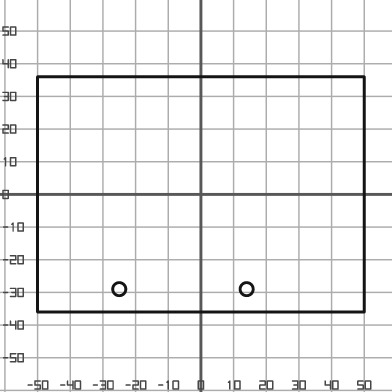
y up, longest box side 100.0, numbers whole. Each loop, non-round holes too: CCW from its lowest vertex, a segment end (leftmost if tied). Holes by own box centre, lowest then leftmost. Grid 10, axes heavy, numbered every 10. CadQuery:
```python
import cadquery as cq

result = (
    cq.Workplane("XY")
    .moveTo(-50.0, -36.0)
    .lineTo(50.0, -36.0)
    .lineTo(50.0, 36.0)
    .lineTo(-50.0, 36.0)
    .close()
    .moveTo(-25.0, -29.0)
    .circle(2.0)
    .moveTo(14.0, -29.0)
    .circle(2.0)
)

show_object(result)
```